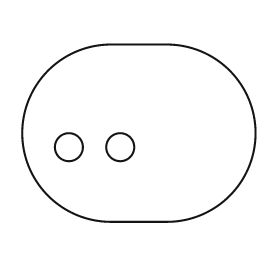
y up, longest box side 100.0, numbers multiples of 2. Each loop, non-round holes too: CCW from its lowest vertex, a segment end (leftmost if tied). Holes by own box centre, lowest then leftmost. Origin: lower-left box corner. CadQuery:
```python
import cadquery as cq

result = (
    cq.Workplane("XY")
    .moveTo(38.0, 0.0)
    .lineTo(62.0, 0.0)
    .threePointArc((100.0, 38.0), (62.0, 76.0))
    .lineTo(38.0, 76.0)
    .threePointArc((0.0, 38.0), (38.0, 0.0))
    .close()
    .moveTo(20.0, 32.0)
    .circle(6.0)
    .moveTo(42.0, 32.0)
    .circle(6.0)
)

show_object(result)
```